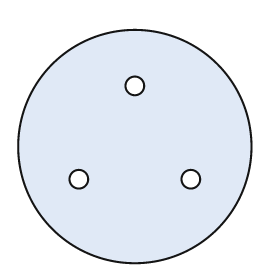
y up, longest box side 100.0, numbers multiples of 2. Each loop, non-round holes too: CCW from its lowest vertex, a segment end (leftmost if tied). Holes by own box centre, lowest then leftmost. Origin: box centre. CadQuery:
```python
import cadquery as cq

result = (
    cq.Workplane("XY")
    .moveTo(0.0, 0.0)
    .circle(50.0)
    .moveTo(-24.0, -14.0)
    .circle(4.0)
    .moveTo(24.0, -14.0)
    .circle(4.0)
    .moveTo(0.0, 26.0)
    .circle(4.0)
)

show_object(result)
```